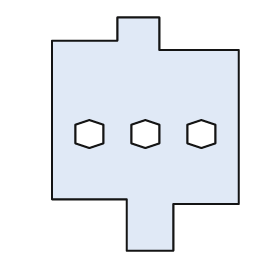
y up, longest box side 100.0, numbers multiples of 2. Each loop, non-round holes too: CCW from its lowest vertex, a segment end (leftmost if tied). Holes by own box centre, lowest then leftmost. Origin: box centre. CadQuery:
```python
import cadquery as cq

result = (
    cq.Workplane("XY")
    .moveTo(-8.0, -50.0)
    .lineTo(12.0, -50.0)
    .lineTo(12.0, -30.0)
    .lineTo(40.0, -30.0)
    .lineTo(40.0, 36.0)
    .lineTo(6.0, 36.0)
    .lineTo(6.0, 50.0)
    .lineTo(-12.0, 50.0)
    .lineTo(-12.0, 40.0)
    .lineTo(-40.0, 40.0)
    .lineTo(-40.0, -28.0)
    .lineTo(-8.0, -28.0)
    .close()
    .moveTo(-24.0, -6.0)
    .lineTo(-18.0, -4.0)
    .lineTo(-18.0, 4.0)
    .lineTo(-24.0, 6.0)
    .lineTo(-30.0, 4.0)
    .lineTo(-30.0, -4.0)
    .close()
    .moveTo(0.0, -6.0)
    .lineTo(6.0, -4.0)
    .lineTo(6.0, 4.0)
    .lineTo(0.0, 6.0)
    .lineTo(-6.0, 4.0)
    .lineTo(-6.0, -4.0)
    .close()
    .moveTo(24.0, -6.0)
    .lineTo(30.0, -4.0)
    .lineTo(30.0, 4.0)
    .lineTo(24.0, 6.0)
    .lineTo(18.0, 4.0)
    .lineTo(18.0, -4.0)
    .close()
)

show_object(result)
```